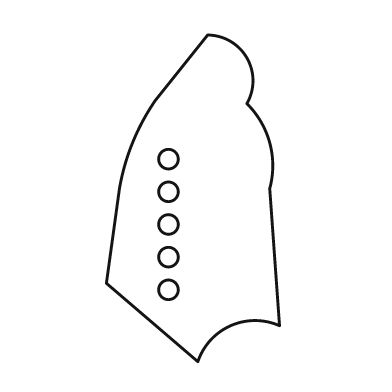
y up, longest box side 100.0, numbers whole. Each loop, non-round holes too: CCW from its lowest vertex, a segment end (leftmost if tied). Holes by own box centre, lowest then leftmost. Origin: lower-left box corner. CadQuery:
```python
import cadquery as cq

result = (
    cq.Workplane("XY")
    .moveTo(28.0, 0.0)
    .threePointArc((38.0, 11.0), (53.0, 11.0))
    .lineTo(50.0, 53.0)
    .threePointArc((50.0, 67.0), (43.0, 79.0))
    .threePointArc((43.0, 93.0), (31.0, 100.0))
    .lineTo(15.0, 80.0)
    .threePointArc((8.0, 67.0), (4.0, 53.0))
    .lineTo(0.0, 24.0)
    .close()
    .moveTo(19.0, 22.0)
    .circle(3.0)
    .moveTo(19.0, 32.0)
    .circle(3.0)
    .moveTo(19.0, 42.0)
    .circle(3.0)
    .moveTo(19.0, 52.0)
    .circle(3.0)
    .moveTo(19.0, 62.0)
    .circle(3.0)
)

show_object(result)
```